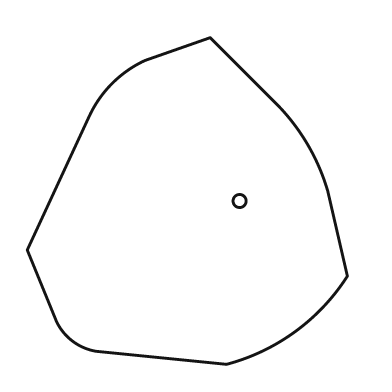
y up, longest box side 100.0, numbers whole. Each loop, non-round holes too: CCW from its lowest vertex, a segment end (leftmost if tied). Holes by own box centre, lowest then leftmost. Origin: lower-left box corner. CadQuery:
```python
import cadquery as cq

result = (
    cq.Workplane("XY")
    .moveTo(61.0, 0.0)
    .threePointArc((82.0, 10.0), (98.0, 27.0))
    .lineTo(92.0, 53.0)
    .threePointArc((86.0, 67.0), (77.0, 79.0))
    .lineTo(56.0, 100.0)
    .lineTo(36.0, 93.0)
    .threePointArc((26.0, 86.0), (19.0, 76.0))
    .lineTo(0.0, 35.0)
    .lineTo(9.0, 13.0)
    .threePointArc((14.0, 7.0), (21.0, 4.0))
    .close()
    .moveTo(65.0, 50.0)
    .circle(2.0)
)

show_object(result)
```